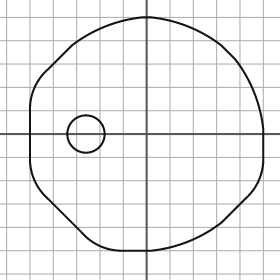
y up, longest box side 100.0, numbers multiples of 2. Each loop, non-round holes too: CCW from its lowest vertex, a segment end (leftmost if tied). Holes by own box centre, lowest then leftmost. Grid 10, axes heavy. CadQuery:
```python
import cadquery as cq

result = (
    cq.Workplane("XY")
    .moveTo(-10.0, -50.0)
    .lineTo(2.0, -50.0)
    .threePointArc((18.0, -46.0), (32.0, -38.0))
    .lineTo(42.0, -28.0)
    .threePointArc((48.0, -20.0), (50.0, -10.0))
    .lineTo(50.0, 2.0)
    .threePointArc((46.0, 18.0), (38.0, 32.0))
    .lineTo(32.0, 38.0)
    .threePointArc((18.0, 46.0), (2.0, 50.0))
    .lineTo(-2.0, 50.0)
    .threePointArc((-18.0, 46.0), (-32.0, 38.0))
    .lineTo(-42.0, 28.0)
    .threePointArc((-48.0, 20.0), (-50.0, 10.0))
    .lineTo(-50.0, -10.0)
    .threePointArc((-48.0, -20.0), (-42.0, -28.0))
    .lineTo(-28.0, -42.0)
    .threePointArc((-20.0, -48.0), (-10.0, -50.0))
    .close()
    .moveTo(-26.0, 0.0)
    .circle(8.0)
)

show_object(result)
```